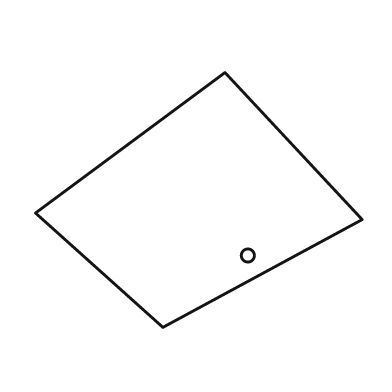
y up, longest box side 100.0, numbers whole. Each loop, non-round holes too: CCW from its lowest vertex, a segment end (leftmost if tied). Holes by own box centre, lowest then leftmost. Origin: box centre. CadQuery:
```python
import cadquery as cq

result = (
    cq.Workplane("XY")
    .moveTo(-11.0, -39.0)
    .lineTo(50.0, -6.0)
    .lineTo(8.0, 39.0)
    .lineTo(-50.0, -4.0)
    .close()
    .moveTo(15.0, -17.0)
    .circle(2.0)
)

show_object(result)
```